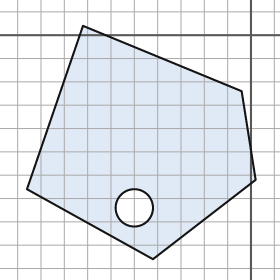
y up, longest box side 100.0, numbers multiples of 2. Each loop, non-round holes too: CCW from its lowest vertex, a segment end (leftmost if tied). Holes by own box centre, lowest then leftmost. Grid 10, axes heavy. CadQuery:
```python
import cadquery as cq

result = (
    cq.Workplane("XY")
    .moveTo(-42.0, -96.0)
    .lineTo(2.0, -62.0)
    .lineTo(-4.0, -24.0)
    .lineTo(-72.0, 4.0)
    .lineTo(-96.0, -66.0)
    .close()
    .moveTo(-50.0, -74.0)
    .circle(8.0)
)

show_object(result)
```